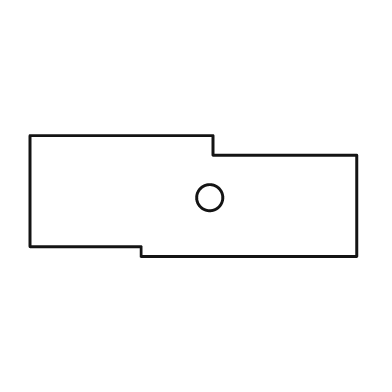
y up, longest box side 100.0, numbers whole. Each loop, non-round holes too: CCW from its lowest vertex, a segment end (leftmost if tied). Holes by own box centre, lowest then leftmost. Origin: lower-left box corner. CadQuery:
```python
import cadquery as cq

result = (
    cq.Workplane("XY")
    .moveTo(34.0, 0.0)
    .lineTo(100.0, 0.0)
    .lineTo(100.0, 31.0)
    .lineTo(56.0, 31.0)
    .lineTo(56.0, 37.0)
    .lineTo(0.0, 37.0)
    .lineTo(0.0, 3.0)
    .lineTo(34.0, 3.0)
    .close()
    .moveTo(55.0, 18.0)
    .circle(4.0)
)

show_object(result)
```